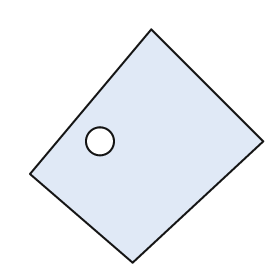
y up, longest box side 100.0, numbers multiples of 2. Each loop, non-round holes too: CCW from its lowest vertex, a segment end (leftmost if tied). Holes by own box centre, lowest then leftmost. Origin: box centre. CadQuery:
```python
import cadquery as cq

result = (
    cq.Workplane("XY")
    .moveTo(-6.0, -50.0)
    .lineTo(50.0, 2.0)
    .lineTo(2.0, 50.0)
    .lineTo(-50.0, -12.0)
    .close()
    .moveTo(-20.0, 2.0)
    .circle(6.0)
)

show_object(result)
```